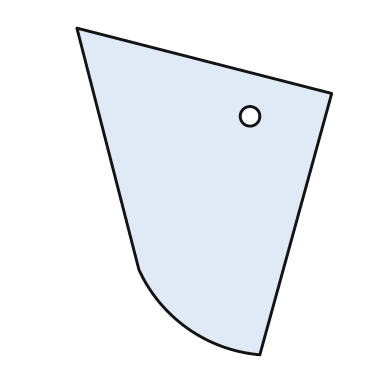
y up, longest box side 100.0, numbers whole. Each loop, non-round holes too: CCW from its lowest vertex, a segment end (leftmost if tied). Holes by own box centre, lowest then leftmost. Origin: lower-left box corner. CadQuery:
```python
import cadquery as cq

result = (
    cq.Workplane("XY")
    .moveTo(56.0, 0.0)
    .lineTo(78.0, 80.0)
    .lineTo(0.0, 100.0)
    .lineTo(19.0, 26.0)
    .threePointArc((34.0, 8.0), (56.0, 0.0))
    .close()
    .moveTo(53.0, 73.0)
    .circle(3.0)
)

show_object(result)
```